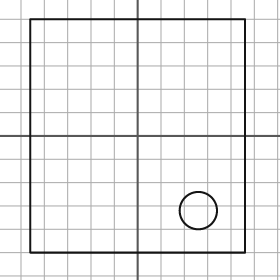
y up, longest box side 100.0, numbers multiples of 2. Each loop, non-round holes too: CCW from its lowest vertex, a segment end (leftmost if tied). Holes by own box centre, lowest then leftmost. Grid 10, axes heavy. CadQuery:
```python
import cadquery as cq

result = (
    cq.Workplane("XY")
    .moveTo(-46.0, -50.0)
    .lineTo(46.0, -50.0)
    .lineTo(46.0, 50.0)
    .lineTo(-46.0, 50.0)
    .close()
    .moveTo(26.0, -32.0)
    .circle(8.0)
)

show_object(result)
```